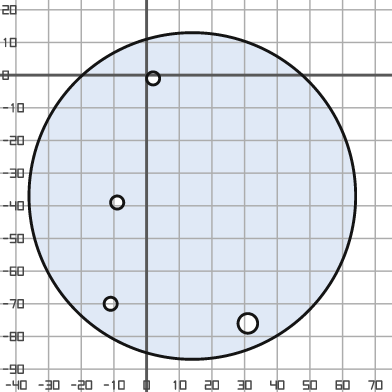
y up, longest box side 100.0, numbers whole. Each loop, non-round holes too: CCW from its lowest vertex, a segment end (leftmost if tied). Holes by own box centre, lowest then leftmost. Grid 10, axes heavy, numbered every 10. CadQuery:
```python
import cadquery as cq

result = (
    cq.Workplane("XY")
    .moveTo(14.0, -37.0)
    .circle(50.0)
    .moveTo(31.0, -76.0)
    .circle(3.0)
    .moveTo(-11.0, -70.0)
    .circle(2.0)
    .moveTo(-9.0, -39.0)
    .circle(2.0)
    .moveTo(2.0, -1.0)
    .circle(2.0)
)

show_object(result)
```